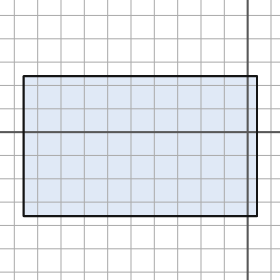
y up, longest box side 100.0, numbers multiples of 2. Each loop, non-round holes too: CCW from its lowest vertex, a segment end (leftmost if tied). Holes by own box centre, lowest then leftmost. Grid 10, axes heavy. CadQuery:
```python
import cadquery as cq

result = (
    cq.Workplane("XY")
    .moveTo(-96.0, -36.0)
    .lineTo(4.0, -36.0)
    .lineTo(4.0, 24.0)
    .lineTo(-96.0, 24.0)
    .close()
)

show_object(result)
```